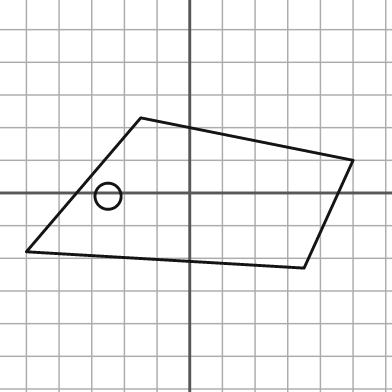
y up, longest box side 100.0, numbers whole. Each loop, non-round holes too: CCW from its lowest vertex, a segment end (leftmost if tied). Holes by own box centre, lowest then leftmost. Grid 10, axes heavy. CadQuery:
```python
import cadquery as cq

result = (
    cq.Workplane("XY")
    .moveTo(35.0, -23.0)
    .lineTo(50.0, 10.0)
    .lineTo(-15.0, 23.0)
    .lineTo(-50.0, -18.0)
    .close()
    .moveTo(-25.0, -1.0)
    .circle(4.0)
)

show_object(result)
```